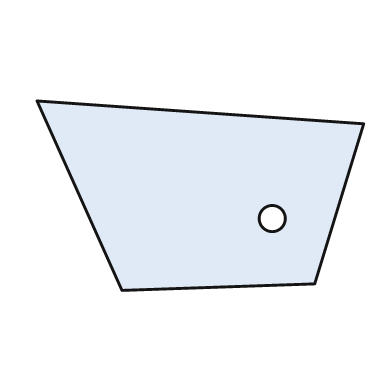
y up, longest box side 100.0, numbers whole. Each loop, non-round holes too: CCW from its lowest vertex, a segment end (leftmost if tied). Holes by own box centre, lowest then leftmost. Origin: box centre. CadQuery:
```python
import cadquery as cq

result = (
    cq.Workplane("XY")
    .moveTo(-24.0, -29.0)
    .lineTo(35.0, -27.0)
    .lineTo(50.0, 22.0)
    .lineTo(-50.0, 29.0)
    .close()
    .moveTo(22.0, -7.0)
    .circle(4.0)
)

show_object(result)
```